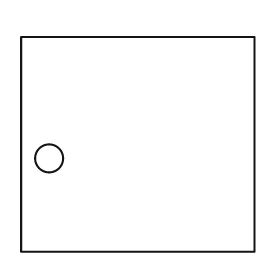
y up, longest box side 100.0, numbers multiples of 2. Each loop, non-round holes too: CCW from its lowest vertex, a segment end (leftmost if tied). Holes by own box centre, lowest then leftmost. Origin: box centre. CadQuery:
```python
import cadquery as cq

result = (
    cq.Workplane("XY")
    .moveTo(-50.0, -46.0)
    .lineTo(50.0, -46.0)
    .lineTo(50.0, 46.0)
    .lineTo(-50.0, 46.0)
    .close()
    .moveTo(-38.0, -6.0)
    .circle(6.0)
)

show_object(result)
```